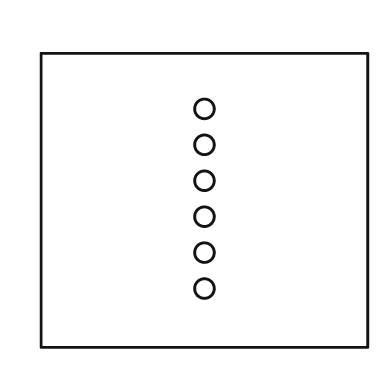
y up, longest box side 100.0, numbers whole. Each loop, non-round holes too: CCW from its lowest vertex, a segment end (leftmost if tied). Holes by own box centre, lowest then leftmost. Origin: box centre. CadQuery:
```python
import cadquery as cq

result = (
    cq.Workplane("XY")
    .moveTo(-50.0, -45.0)
    .lineTo(50.0, -45.0)
    .lineTo(50.0, 45.0)
    .lineTo(-50.0, 45.0)
    .close()
    .moveTo(0.0, -27.0)
    .circle(3.0)
    .moveTo(0.0, -16.0)
    .circle(3.0)
    .moveTo(0.0, -5.0)
    .circle(3.0)
    .moveTo(0.0, 6.0)
    .circle(3.0)
    .moveTo(0.0, 17.0)
    .circle(3.0)
    .moveTo(0.0, 28.0)
    .circle(3.0)
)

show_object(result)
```